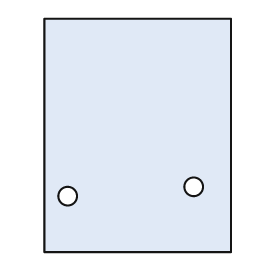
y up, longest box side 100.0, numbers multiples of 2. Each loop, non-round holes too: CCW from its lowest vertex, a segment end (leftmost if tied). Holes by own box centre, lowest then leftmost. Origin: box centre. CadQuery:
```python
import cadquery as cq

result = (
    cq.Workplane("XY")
    .moveTo(-40.0, -50.0)
    .lineTo(40.0, -50.0)
    .lineTo(40.0, 50.0)
    .lineTo(-40.0, 50.0)
    .close()
    .moveTo(-30.0, -26.0)
    .circle(4.0)
    .moveTo(24.0, -22.0)
    .circle(4.0)
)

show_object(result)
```